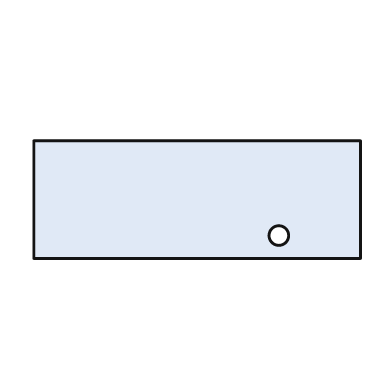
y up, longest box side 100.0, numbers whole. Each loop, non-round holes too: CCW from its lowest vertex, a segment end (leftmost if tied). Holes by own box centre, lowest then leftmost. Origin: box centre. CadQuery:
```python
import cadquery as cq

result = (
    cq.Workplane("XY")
    .moveTo(-50.0, -18.0)
    .lineTo(50.0, -18.0)
    .lineTo(50.0, 18.0)
    .lineTo(-50.0, 18.0)
    .close()
    .moveTo(25.0, -11.0)
    .circle(3.0)
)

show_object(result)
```